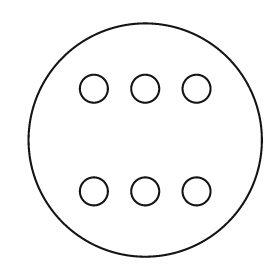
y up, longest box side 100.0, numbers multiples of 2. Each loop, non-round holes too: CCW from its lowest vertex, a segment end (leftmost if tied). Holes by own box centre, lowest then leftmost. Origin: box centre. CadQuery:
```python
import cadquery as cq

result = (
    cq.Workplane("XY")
    .moveTo(0.0, 0.0)
    .circle(50.0)
    .moveTo(-22.0, -22.0)
    .circle(6.0)
    .moveTo(0.0, -22.0)
    .circle(6.0)
    .moveTo(22.0, -22.0)
    .circle(6.0)
    .moveTo(-22.0, 22.0)
    .circle(6.0)
    .moveTo(0.0, 22.0)
    .circle(6.0)
    .moveTo(22.0, 22.0)
    .circle(6.0)
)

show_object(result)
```